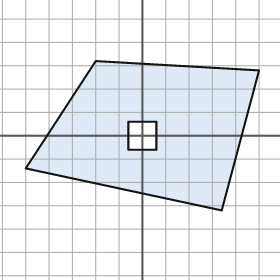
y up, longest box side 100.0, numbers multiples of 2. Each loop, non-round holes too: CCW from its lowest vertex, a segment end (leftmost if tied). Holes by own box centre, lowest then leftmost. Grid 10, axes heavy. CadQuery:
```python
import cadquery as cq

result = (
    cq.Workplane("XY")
    .moveTo(34.0, -32.0)
    .lineTo(50.0, 28.0)
    .lineTo(-20.0, 32.0)
    .lineTo(-50.0, -14.0)
    .close()
    .moveTo(-6.0, -6.0)
    .lineTo(6.0, -6.0)
    .lineTo(6.0, 6.0)
    .lineTo(-6.0, 6.0)
    .close()
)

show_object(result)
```